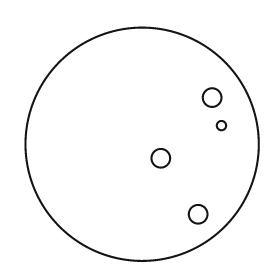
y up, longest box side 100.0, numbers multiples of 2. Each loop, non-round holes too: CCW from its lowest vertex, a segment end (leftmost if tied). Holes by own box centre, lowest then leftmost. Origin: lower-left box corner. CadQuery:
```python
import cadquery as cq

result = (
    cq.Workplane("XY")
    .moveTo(50.0, 50.0)
    .circle(50.0)
    .moveTo(74.0, 20.0)
    .circle(4.0)
    .moveTo(58.0, 44.0)
    .circle(4.0)
    .moveTo(84.0, 58.0)
    .circle(2.0)
    .moveTo(80.0, 70.0)
    .circle(4.0)
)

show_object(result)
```